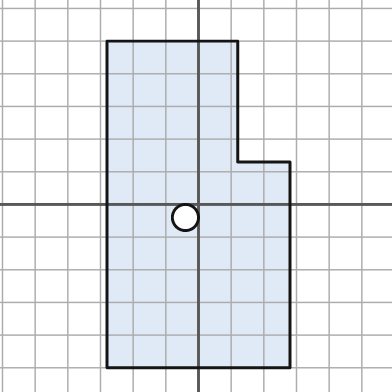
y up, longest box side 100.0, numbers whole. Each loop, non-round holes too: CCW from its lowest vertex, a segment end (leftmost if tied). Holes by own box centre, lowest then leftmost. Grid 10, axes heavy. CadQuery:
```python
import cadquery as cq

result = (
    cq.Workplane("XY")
    .moveTo(-28.0, -50.0)
    .lineTo(28.0, -50.0)
    .lineTo(28.0, 13.0)
    .lineTo(12.0, 13.0)
    .lineTo(12.0, 50.0)
    .lineTo(-28.0, 50.0)
    .close()
    .moveTo(-4.0, -4.0)
    .circle(4.0)
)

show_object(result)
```